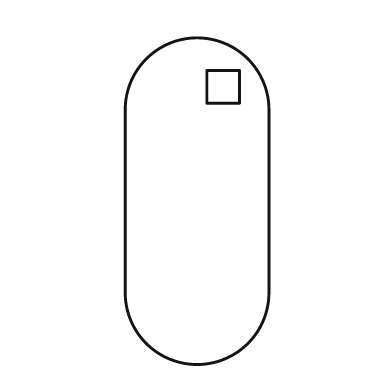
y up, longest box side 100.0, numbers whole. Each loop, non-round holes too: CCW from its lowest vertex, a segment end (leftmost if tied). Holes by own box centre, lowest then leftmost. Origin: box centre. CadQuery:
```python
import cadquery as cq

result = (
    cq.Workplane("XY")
    .moveTo(-22.0, -28.0)
    .threePointArc((0.0, -50.0), (22.0, -28.0))
    .lineTo(22.0, 28.0)
    .threePointArc((0.0, 50.0), (-22.0, 28.0))
    .close()
    .moveTo(3.0, 30.0)
    .lineTo(13.0, 30.0)
    .lineTo(13.0, 40.0)
    .lineTo(3.0, 40.0)
    .close()
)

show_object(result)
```